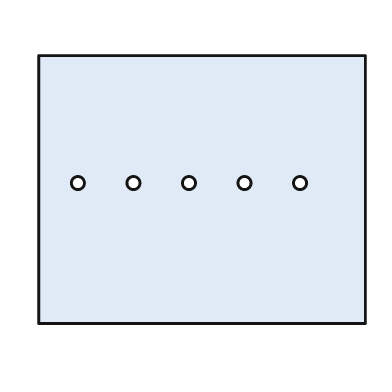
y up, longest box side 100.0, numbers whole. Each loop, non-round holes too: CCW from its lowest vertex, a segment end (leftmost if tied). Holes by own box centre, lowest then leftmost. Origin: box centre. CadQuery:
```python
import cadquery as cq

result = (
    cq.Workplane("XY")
    .moveTo(-50.0, -41.0)
    .lineTo(50.0, -41.0)
    .lineTo(50.0, 41.0)
    .lineTo(-50.0, 41.0)
    .close()
    .moveTo(-38.0, 2.0)
    .circle(2.0)
    .moveTo(-21.0, 2.0)
    .circle(2.0)
    .moveTo(-4.0, 2.0)
    .circle(2.0)
    .moveTo(13.0, 2.0)
    .circle(2.0)
    .moveTo(30.0, 2.0)
    .circle(2.0)
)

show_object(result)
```